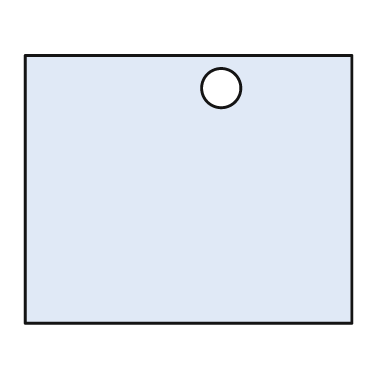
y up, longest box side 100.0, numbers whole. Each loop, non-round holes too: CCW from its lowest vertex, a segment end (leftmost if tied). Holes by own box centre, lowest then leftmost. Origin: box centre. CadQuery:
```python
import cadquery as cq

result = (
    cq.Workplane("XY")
    .moveTo(-50.0, -41.0)
    .lineTo(50.0, -41.0)
    .lineTo(50.0, 41.0)
    .lineTo(-50.0, 41.0)
    .close()
    .moveTo(10.0, 31.0)
    .circle(6.0)
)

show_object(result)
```